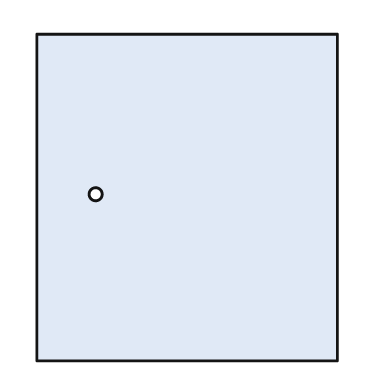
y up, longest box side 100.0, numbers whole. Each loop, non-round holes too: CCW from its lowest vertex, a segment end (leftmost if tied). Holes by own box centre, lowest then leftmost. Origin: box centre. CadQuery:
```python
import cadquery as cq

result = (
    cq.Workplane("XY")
    .moveTo(-46.0, -50.0)
    .lineTo(46.0, -50.0)
    .lineTo(46.0, 50.0)
    .lineTo(-46.0, 50.0)
    .close()
    .moveTo(-28.0, 1.0)
    .circle(2.0)
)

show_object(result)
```